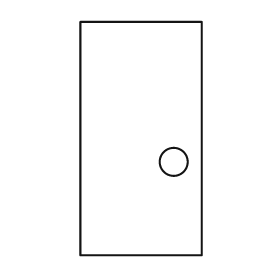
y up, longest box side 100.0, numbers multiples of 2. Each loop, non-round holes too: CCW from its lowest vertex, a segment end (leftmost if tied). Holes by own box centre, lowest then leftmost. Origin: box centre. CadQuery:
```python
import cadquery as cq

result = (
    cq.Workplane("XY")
    .moveTo(-26.0, -50.0)
    .lineTo(26.0, -50.0)
    .lineTo(26.0, 50.0)
    .lineTo(-26.0, 50.0)
    .close()
    .moveTo(14.0, -10.0)
    .circle(6.0)
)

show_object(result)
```